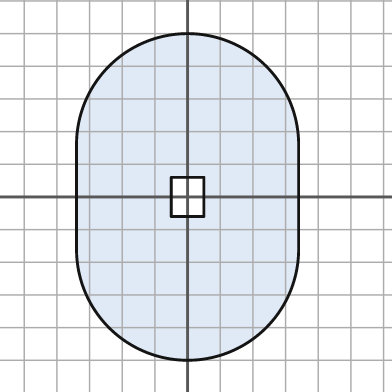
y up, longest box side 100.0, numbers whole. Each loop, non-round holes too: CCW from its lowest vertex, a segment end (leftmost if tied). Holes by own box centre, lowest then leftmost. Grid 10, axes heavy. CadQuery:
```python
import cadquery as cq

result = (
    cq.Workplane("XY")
    .moveTo(-34.0, -16.0)
    .threePointArc((0.0, -50.0), (34.0, -16.0))
    .lineTo(34.0, 16.0)
    .threePointArc((0.0, 50.0), (-34.0, 16.0))
    .close()
    .moveTo(-5.0, -6.0)
    .lineTo(5.0, -6.0)
    .lineTo(5.0, 6.0)
    .lineTo(-5.0, 6.0)
    .close()
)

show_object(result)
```